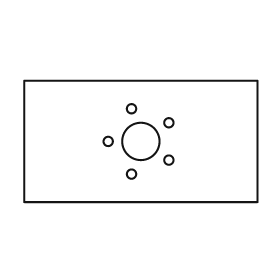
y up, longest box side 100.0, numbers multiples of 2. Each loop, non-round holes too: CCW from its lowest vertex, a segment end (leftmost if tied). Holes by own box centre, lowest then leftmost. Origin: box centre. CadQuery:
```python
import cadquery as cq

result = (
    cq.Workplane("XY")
    .moveTo(-50.0, -26.0)
    .lineTo(50.0, -26.0)
    .lineTo(50.0, 26.0)
    .lineTo(-50.0, 26.0)
    .close()
    .moveTo(-4.0, -14.0)
    .circle(2.0)
    .moveTo(12.0, -8.0)
    .circle(2.0)
    .moveTo(-14.0, 0.0)
    .circle(2.0)
    .moveTo(0.0, 0.0)
    .circle(8.0)
    .moveTo(12.0, 8.0)
    .circle(2.0)
    .moveTo(-4.0, 14.0)
    .circle(2.0)
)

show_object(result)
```